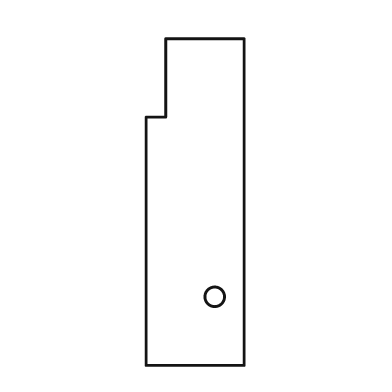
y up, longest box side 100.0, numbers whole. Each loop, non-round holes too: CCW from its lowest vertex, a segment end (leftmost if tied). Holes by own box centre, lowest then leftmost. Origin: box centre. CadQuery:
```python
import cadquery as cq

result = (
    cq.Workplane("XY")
    .moveTo(-15.0, -50.0)
    .lineTo(15.0, -50.0)
    .lineTo(15.0, 50.0)
    .lineTo(-9.0, 50.0)
    .lineTo(-9.0, 26.0)
    .lineTo(-15.0, 26.0)
    .close()
    .moveTo(6.0, -29.0)
    .circle(3.0)
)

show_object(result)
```